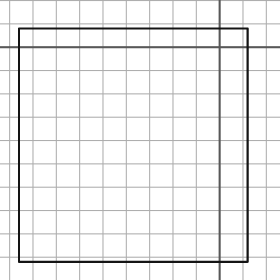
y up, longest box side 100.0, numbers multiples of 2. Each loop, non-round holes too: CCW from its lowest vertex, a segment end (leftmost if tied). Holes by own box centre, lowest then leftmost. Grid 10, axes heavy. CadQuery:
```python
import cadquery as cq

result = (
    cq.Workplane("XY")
    .moveTo(-86.0, -92.0)
    .lineTo(12.0, -92.0)
    .lineTo(12.0, 8.0)
    .lineTo(-86.0, 8.0)
    .close()
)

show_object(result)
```